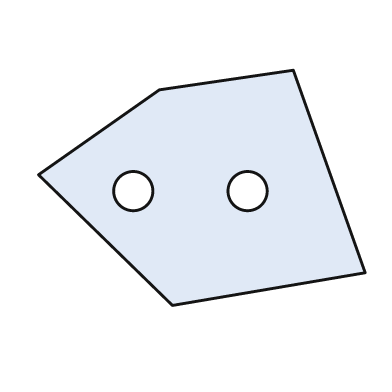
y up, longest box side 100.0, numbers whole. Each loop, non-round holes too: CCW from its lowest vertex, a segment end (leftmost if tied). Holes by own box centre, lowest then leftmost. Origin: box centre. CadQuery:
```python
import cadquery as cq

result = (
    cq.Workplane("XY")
    .moveTo(-9.0, -36.0)
    .lineTo(50.0, -26.0)
    .lineTo(28.0, 36.0)
    .lineTo(-13.0, 30.0)
    .lineTo(-50.0, 4.0)
    .close()
    .moveTo(-21.0, -1.0)
    .circle(6.0)
    .moveTo(14.0, -1.0)
    .circle(6.0)
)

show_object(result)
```